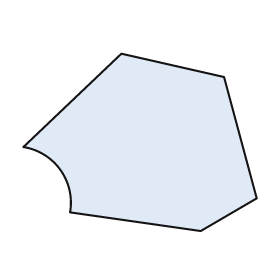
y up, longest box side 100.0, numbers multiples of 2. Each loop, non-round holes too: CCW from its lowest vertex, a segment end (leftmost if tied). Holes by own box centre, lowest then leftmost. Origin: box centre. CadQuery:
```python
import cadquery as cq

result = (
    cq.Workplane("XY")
    .moveTo(26.0, -38.0)
    .lineTo(50.0, -24.0)
    .lineTo(36.0, 28.0)
    .lineTo(-8.0, 38.0)
    .lineTo(-50.0, -2.0)
    .threePointArc((-34.0, -12.0), (-30.0, -30.0))
    .close()
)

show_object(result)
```